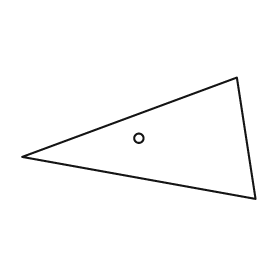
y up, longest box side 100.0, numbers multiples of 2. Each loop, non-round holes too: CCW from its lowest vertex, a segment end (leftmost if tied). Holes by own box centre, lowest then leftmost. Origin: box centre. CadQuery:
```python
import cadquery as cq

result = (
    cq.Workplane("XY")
    .moveTo(50.0, -26.0)
    .lineTo(42.0, 26.0)
    .lineTo(-50.0, -8.0)
    .close()
    .moveTo(0.0, 0.0)
    .circle(2.0)
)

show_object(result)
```